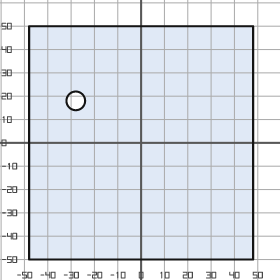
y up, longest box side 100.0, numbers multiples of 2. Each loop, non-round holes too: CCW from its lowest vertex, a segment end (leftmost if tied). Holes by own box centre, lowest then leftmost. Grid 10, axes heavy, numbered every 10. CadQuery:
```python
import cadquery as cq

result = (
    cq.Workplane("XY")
    .moveTo(-48.0, -50.0)
    .lineTo(48.0, -50.0)
    .lineTo(48.0, 50.0)
    .lineTo(-48.0, 50.0)
    .close()
    .moveTo(-28.0, 18.0)
    .circle(4.0)
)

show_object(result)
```